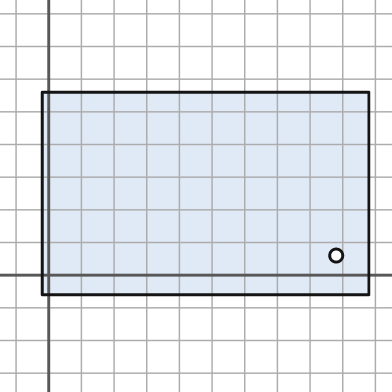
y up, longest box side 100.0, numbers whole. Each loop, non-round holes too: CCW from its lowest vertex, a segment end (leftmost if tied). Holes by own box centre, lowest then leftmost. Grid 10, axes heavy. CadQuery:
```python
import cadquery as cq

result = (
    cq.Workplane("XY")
    .moveTo(-2.0, -6.0)
    .lineTo(98.0, -6.0)
    .lineTo(98.0, 56.0)
    .lineTo(-2.0, 56.0)
    .close()
    .moveTo(88.0, 6.0)
    .circle(2.0)
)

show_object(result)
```